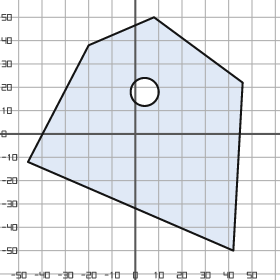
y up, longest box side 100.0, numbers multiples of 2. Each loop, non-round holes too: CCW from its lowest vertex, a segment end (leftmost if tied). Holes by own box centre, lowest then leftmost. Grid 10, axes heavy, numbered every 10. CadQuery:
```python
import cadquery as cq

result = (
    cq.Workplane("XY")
    .moveTo(42.0, -50.0)
    .lineTo(46.0, 22.0)
    .lineTo(8.0, 50.0)
    .lineTo(-20.0, 38.0)
    .lineTo(-46.0, -12.0)
    .close()
    .moveTo(4.0, 18.0)
    .circle(6.0)
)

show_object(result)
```